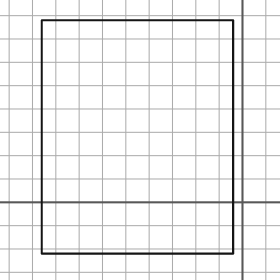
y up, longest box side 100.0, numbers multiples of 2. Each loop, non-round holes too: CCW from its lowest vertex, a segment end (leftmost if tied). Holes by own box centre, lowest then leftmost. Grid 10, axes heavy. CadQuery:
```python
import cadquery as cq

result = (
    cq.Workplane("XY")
    .moveTo(-86.0, -22.0)
    .lineTo(-4.0, -22.0)
    .lineTo(-4.0, 78.0)
    .lineTo(-86.0, 78.0)
    .close()
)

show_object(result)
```